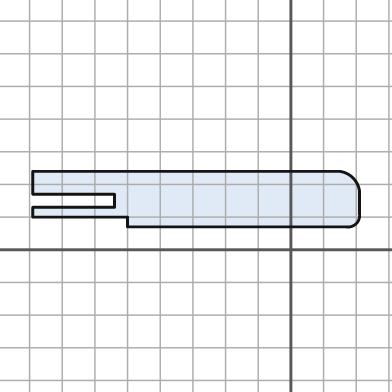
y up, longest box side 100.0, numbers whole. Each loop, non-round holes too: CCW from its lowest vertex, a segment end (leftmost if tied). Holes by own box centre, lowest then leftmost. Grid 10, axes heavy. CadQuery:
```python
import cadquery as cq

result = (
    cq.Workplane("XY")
    .moveTo(-50.0, 7.0)
    .lineTo(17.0, 7.0)
    .threePointArc((20.0, 8.0), (21.0, 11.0))
    .lineTo(21.0, 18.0)
    .threePointArc((19.0, 22.0), (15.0, 24.0))
    .lineTo(-79.0, 24.0)
    .lineTo(-79.0, 17.0)
    .lineTo(-54.0, 17.0)
    .lineTo(-54.0, 13.0)
    .lineTo(-79.0, 13.0)
    .lineTo(-79.0, 10.0)
    .lineTo(-50.0, 10.0)
    .close()
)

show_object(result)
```